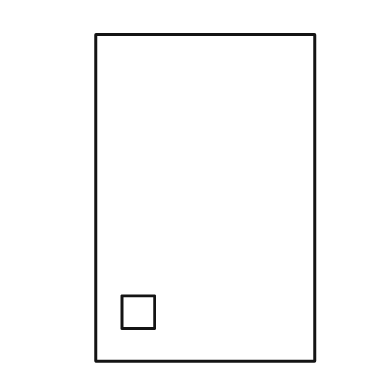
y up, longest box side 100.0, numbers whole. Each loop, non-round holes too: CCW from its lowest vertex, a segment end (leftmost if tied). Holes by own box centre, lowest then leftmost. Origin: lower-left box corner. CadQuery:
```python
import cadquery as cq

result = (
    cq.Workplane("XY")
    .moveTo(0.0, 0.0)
    .lineTo(67.0, 0.0)
    .lineTo(67.0, 100.0)
    .lineTo(0.0, 100.0)
    .close()
    .moveTo(8.0, 10.0)
    .lineTo(18.0, 10.0)
    .lineTo(18.0, 20.0)
    .lineTo(8.0, 20.0)
    .close()
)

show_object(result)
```